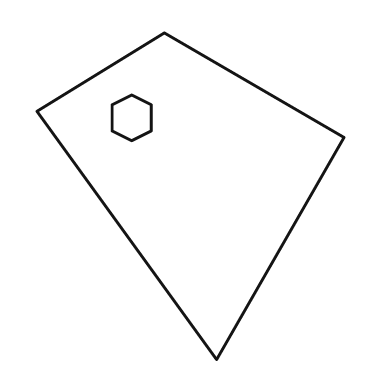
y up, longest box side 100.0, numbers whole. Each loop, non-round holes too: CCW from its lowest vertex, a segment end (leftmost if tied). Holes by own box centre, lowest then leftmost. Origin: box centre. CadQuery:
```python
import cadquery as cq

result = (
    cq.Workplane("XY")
    .moveTo(8.0, -50.0)
    .lineTo(47.0, 18.0)
    .lineTo(-8.0, 50.0)
    .lineTo(-47.0, 26.0)
    .close()
    .moveTo(-18.0, 17.0)
    .lineTo(-12.0, 20.0)
    .lineTo(-12.0, 28.0)
    .lineTo(-18.0, 31.0)
    .lineTo(-24.0, 28.0)
    .lineTo(-24.0, 20.0)
    .close()
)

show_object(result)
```